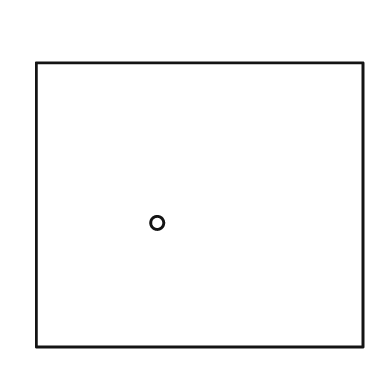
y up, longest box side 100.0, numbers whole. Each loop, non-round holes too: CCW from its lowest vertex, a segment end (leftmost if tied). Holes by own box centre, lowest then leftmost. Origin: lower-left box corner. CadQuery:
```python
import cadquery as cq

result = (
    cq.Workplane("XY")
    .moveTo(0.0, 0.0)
    .lineTo(100.0, 0.0)
    .lineTo(100.0, 87.0)
    .lineTo(0.0, 87.0)
    .close()
    .moveTo(37.0, 38.0)
    .circle(2.0)
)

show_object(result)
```